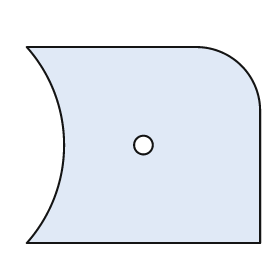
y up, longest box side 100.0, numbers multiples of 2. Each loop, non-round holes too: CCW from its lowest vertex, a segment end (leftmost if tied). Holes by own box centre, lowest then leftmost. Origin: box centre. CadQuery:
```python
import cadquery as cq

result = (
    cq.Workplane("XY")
    .moveTo(-50.0, -42.0)
    .lineTo(50.0, -42.0)
    .lineTo(50.0, 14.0)
    .threePointArc((42.0, 34.0), (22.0, 42.0))
    .lineTo(-50.0, 42.0)
    .threePointArc((-34.0, 0.0), (-50.0, -42.0))
    .close()
    .moveTo(0.0, 0.0)
    .circle(4.0)
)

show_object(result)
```